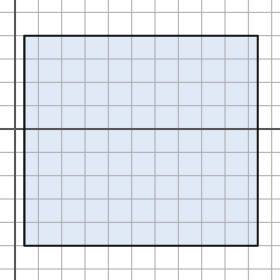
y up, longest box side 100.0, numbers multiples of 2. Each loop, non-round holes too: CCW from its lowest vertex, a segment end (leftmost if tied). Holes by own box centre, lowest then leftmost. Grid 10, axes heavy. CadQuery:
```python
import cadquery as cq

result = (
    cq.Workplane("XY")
    .moveTo(4.0, -50.0)
    .lineTo(104.0, -50.0)
    .lineTo(104.0, 40.0)
    .lineTo(4.0, 40.0)
    .close()
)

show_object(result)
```